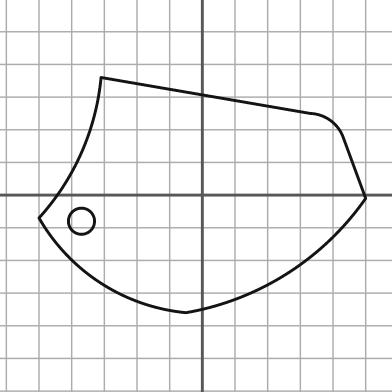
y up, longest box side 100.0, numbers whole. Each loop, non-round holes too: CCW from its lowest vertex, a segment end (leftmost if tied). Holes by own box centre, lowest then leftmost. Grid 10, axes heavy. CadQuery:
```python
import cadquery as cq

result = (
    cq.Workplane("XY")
    .moveTo(-5.0, -36.0)
    .threePointArc((26.0, -24.0), (50.0, -1.0))
    .lineTo(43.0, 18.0)
    .threePointArc((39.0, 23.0), (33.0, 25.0))
    .lineTo(-31.0, 36.0)
    .threePointArc((-37.0, 13.0), (-50.0, -7.0))
    .threePointArc((-31.0, -27.0), (-5.0, -36.0))
    .close()
    .moveTo(-37.0, -8.0)
    .circle(4.0)
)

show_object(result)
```